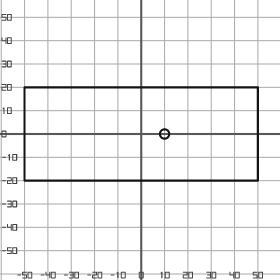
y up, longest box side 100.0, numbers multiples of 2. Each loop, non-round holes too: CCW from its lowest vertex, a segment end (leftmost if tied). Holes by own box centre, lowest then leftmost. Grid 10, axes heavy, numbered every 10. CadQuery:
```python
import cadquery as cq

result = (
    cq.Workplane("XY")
    .moveTo(-50.0, -20.0)
    .lineTo(50.0, -20.0)
    .lineTo(50.0, 20.0)
    .lineTo(-50.0, 20.0)
    .close()
    .moveTo(10.0, 0.0)
    .circle(2.0)
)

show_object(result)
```